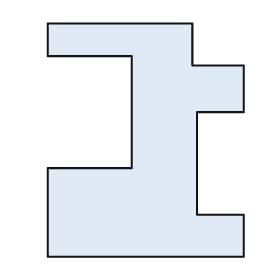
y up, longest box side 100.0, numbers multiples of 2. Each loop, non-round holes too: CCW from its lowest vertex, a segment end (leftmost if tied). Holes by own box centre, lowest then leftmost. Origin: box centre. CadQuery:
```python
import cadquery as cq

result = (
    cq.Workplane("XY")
    .moveTo(-42.0, -50.0)
    .lineTo(42.0, -50.0)
    .lineTo(42.0, -32.0)
    .lineTo(22.0, -32.0)
    .lineTo(22.0, 12.0)
    .lineTo(42.0, 12.0)
    .lineTo(42.0, 32.0)
    .lineTo(20.0, 32.0)
    .lineTo(20.0, 50.0)
    .lineTo(-42.0, 50.0)
    .lineTo(-42.0, 36.0)
    .lineTo(-6.0, 36.0)
    .lineTo(-6.0, -12.0)
    .lineTo(-42.0, -12.0)
    .close()
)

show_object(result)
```